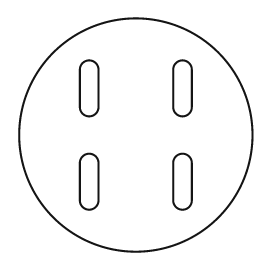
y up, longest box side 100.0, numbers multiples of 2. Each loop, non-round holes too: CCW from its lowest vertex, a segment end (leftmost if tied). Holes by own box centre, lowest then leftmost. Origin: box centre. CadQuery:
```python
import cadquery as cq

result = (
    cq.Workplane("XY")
    .moveTo(0.0, 0.0)
    .circle(50.0)
    .moveTo(-24.0, -28.0)
    .threePointArc((-20.0, -32.0), (-16.0, -28.0))
    .lineTo(-16.0, -12.0)
    .threePointArc((-20.0, -8.0), (-24.0, -12.0))
    .close()
    .moveTo(16.0, -28.0)
    .threePointArc((20.0, -32.0), (24.0, -28.0))
    .lineTo(24.0, -12.0)
    .threePointArc((20.0, -8.0), (16.0, -12.0))
    .close()
    .moveTo(-24.0, 12.0)
    .threePointArc((-20.0, 8.0), (-16.0, 12.0))
    .lineTo(-16.0, 28.0)
    .threePointArc((-20.0, 32.0), (-24.0, 28.0))
    .close()
    .moveTo(16.0, 12.0)
    .threePointArc((20.0, 8.0), (24.0, 12.0))
    .lineTo(24.0, 28.0)
    .threePointArc((20.0, 32.0), (16.0, 28.0))
    .close()
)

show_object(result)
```